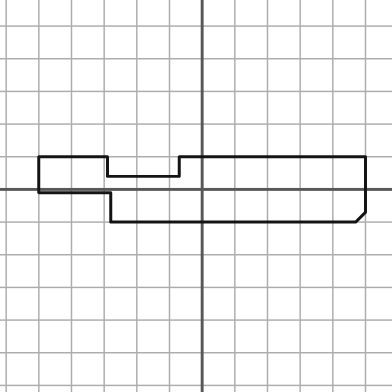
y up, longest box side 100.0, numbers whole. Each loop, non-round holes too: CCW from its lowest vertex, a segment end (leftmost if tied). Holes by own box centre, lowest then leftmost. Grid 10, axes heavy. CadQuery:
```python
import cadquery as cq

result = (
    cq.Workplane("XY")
    .moveTo(-28.0, -10.0)
    .lineTo(47.0, -10.0)
    .lineTo(50.0, -7.0)
    .lineTo(50.0, 10.0)
    .lineTo(-7.0, 10.0)
    .lineTo(-7.0, 4.0)
    .lineTo(-29.0, 4.0)
    .lineTo(-29.0, 10.0)
    .lineTo(-50.0, 10.0)
    .lineTo(-50.0, -1.0)
    .lineTo(-28.0, -1.0)
    .close()
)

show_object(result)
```